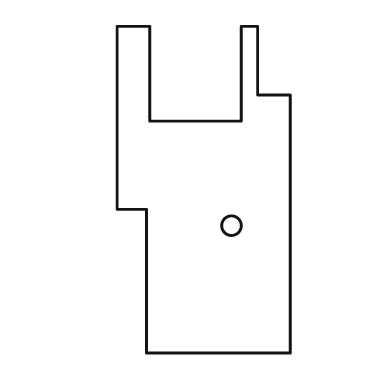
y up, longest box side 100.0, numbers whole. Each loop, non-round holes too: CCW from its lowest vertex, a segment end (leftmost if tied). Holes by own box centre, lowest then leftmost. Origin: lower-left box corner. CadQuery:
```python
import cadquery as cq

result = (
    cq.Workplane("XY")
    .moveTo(9.0, 0.0)
    .lineTo(53.0, 0.0)
    .lineTo(53.0, 79.0)
    .lineTo(43.0, 79.0)
    .lineTo(43.0, 100.0)
    .lineTo(38.0, 100.0)
    .lineTo(38.0, 71.0)
    .lineTo(10.0, 71.0)
    .lineTo(10.0, 100.0)
    .lineTo(0.0, 100.0)
    .lineTo(0.0, 44.0)
    .lineTo(9.0, 44.0)
    .close()
    .moveTo(35.0, 39.0)
    .circle(3.0)
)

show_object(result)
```